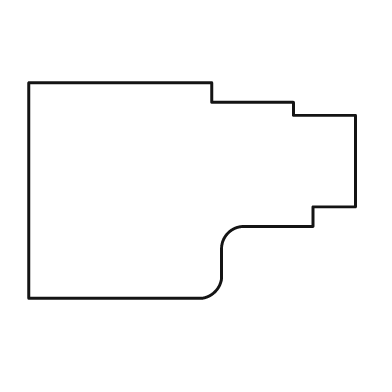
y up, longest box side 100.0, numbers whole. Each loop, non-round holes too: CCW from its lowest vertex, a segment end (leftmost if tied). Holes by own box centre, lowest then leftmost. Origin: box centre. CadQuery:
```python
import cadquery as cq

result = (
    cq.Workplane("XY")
    .moveTo(-50.0, -33.0)
    .lineTo(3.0, -33.0)
    .threePointArc((7.0, -31.0), (9.0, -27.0))
    .lineTo(9.0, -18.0)
    .threePointArc((11.0, -13.0), (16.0, -11.0))
    .lineTo(37.0, -11.0)
    .lineTo(37.0, -5.0)
    .lineTo(50.0, -5.0)
    .lineTo(50.0, 23.0)
    .lineTo(31.0, 23.0)
    .lineTo(31.0, 27.0)
    .lineTo(6.0, 27.0)
    .lineTo(6.0, 33.0)
    .lineTo(-50.0, 33.0)
    .close()
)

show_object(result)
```